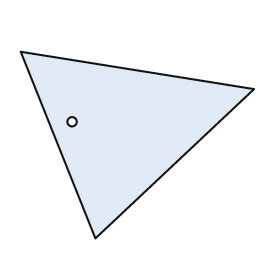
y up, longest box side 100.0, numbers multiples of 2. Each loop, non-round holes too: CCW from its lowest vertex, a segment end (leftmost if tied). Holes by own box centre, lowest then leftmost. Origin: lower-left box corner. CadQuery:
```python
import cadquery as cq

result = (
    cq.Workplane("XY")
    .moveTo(32.0, 0.0)
    .lineTo(100.0, 64.0)
    .lineTo(0.0, 80.0)
    .close()
    .moveTo(22.0, 50.0)
    .circle(2.0)
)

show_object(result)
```